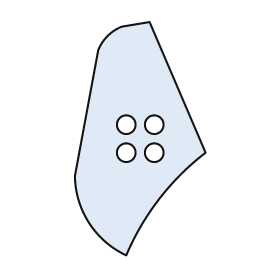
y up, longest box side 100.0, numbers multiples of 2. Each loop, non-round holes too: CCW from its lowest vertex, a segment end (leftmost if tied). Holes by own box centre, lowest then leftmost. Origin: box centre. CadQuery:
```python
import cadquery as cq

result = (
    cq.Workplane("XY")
    .moveTo(-6.0, -50.0)
    .threePointArc((8.0, -26.0), (28.0, -6.0))
    .lineTo(4.0, 50.0)
    .lineTo(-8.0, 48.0)
    .threePointArc((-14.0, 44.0), (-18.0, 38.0))
    .lineTo(-28.0, -16.0)
    .threePointArc((-22.0, -36.0), (-6.0, -50.0))
    .close()
    .moveTo(-6.0, -6.0)
    .circle(4.0)
    .moveTo(6.0, -6.0)
    .circle(4.0)
    .moveTo(-6.0, 6.0)
    .circle(4.0)
    .moveTo(6.0, 6.0)
    .circle(4.0)
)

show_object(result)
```